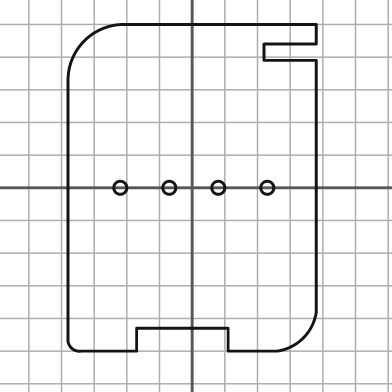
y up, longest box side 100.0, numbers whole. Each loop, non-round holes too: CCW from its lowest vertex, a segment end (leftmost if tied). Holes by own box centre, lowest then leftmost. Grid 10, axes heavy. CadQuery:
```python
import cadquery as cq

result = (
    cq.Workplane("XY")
    .moveTo(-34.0, -50.0)
    .lineTo(-17.0, -50.0)
    .lineTo(-17.0, -43.0)
    .lineTo(11.0, -43.0)
    .lineTo(11.0, -50.0)
    .lineTo(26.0, -50.0)
    .threePointArc((34.0, -46.0), (38.0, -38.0))
    .lineTo(38.0, 39.0)
    .lineTo(22.0, 39.0)
    .lineTo(22.0, 44.0)
    .lineTo(38.0, 44.0)
    .lineTo(38.0, 50.0)
    .lineTo(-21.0, 50.0)
    .threePointArc((-33.0, 45.0), (-38.0, 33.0))
    .lineTo(-38.0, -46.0)
    .threePointArc((-37.0, -49.0), (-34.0, -50.0))
    .close()
    .moveTo(-22.0, 0.0)
    .circle(2.0)
    .moveTo(-7.0, 0.0)
    .circle(2.0)
    .moveTo(8.0, 0.0)
    .circle(2.0)
    .moveTo(23.0, 0.0)
    .circle(2.0)
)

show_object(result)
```